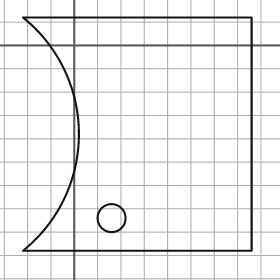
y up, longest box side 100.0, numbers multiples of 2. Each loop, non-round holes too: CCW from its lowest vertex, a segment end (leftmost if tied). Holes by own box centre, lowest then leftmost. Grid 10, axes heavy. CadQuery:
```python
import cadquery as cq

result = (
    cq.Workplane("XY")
    .moveTo(-22.0, -88.0)
    .lineTo(76.0, -88.0)
    .lineTo(76.0, 12.0)
    .lineTo(-22.0, 12.0)
    .threePointArc((2.0, -38.0), (-22.0, -88.0))
    .close()
    .moveTo(16.0, -74.0)
    .circle(6.0)
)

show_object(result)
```